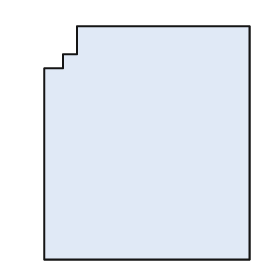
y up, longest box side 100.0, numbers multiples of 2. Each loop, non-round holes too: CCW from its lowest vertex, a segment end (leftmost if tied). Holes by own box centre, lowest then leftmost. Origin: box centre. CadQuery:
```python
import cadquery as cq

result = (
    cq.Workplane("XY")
    .moveTo(-44.0, -50.0)
    .lineTo(44.0, -50.0)
    .lineTo(44.0, 50.0)
    .lineTo(-30.0, 50.0)
    .lineTo(-30.0, 38.0)
    .lineTo(-36.0, 38.0)
    .lineTo(-36.0, 32.0)
    .lineTo(-44.0, 32.0)
    .close()
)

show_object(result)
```